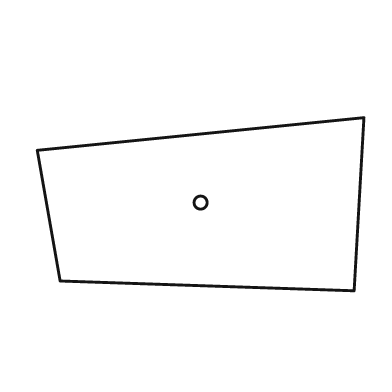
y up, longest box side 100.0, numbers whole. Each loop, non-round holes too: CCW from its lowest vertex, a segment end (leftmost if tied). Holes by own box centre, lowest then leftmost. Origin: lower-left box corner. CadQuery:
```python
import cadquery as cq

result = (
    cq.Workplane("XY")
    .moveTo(97.0, 0.0)
    .lineTo(100.0, 53.0)
    .lineTo(0.0, 43.0)
    .lineTo(7.0, 3.0)
    .close()
    .moveTo(50.0, 27.0)
    .circle(2.0)
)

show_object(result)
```